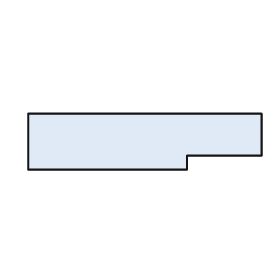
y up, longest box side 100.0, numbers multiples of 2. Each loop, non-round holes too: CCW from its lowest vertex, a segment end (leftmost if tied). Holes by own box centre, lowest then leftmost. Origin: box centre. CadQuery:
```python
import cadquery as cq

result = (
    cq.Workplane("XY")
    .moveTo(-50.0, -12.0)
    .lineTo(18.0, -12.0)
    .lineTo(18.0, -6.0)
    .lineTo(50.0, -6.0)
    .lineTo(50.0, 12.0)
    .lineTo(-50.0, 12.0)
    .close()
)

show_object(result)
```